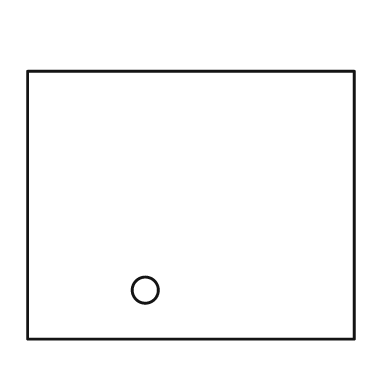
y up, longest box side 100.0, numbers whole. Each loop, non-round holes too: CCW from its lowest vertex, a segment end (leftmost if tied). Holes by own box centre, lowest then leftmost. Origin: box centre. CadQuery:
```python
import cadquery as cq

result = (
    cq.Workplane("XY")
    .moveTo(-50.0, -41.0)
    .lineTo(50.0, -41.0)
    .lineTo(50.0, 41.0)
    .lineTo(-50.0, 41.0)
    .close()
    .moveTo(-14.0, -26.0)
    .circle(4.0)
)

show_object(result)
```